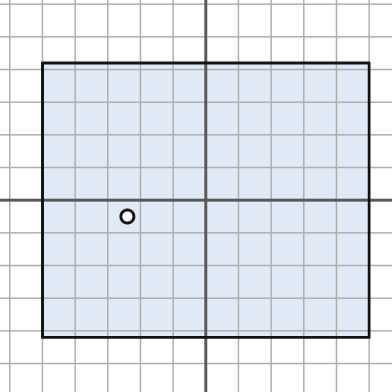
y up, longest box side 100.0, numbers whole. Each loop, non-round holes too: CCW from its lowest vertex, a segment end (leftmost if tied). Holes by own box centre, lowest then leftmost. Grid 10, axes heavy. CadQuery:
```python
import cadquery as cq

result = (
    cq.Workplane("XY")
    .moveTo(-50.0, -42.0)
    .lineTo(50.0, -42.0)
    .lineTo(50.0, 42.0)
    .lineTo(-50.0, 42.0)
    .close()
    .moveTo(-24.0, -5.0)
    .circle(2.0)
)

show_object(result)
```